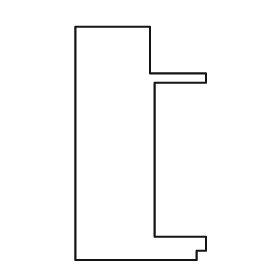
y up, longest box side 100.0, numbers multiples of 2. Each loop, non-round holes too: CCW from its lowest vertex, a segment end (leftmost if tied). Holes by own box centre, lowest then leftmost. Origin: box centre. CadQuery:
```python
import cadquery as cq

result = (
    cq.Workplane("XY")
    .moveTo(-28.0, -50.0)
    .lineTo(24.0, -50.0)
    .lineTo(24.0, -46.0)
    .lineTo(28.0, -46.0)
    .lineTo(28.0, -40.0)
    .lineTo(6.0, -40.0)
    .lineTo(6.0, 26.0)
    .lineTo(28.0, 26.0)
    .lineTo(28.0, 30.0)
    .lineTo(4.0, 30.0)
    .lineTo(4.0, 50.0)
    .lineTo(-28.0, 50.0)
    .close()
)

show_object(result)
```